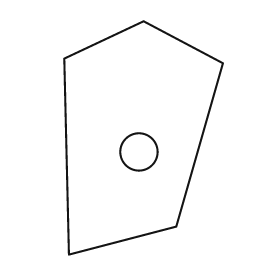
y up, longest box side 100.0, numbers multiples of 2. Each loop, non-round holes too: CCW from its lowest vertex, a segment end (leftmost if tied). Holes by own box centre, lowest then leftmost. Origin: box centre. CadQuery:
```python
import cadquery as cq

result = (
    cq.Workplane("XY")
    .moveTo(-32.0, -50.0)
    .lineTo(14.0, -38.0)
    .lineTo(34.0, 32.0)
    .lineTo(0.0, 50.0)
    .lineTo(-34.0, 34.0)
    .close()
    .moveTo(-2.0, -6.0)
    .circle(8.0)
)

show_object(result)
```